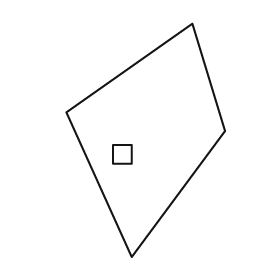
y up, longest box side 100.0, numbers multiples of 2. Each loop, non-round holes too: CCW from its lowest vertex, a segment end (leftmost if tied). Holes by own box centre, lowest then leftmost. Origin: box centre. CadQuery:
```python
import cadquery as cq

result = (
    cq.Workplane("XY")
    .moveTo(-6.0, -50.0)
    .lineTo(34.0, 4.0)
    .lineTo(20.0, 50.0)
    .lineTo(-34.0, 12.0)
    .close()
    .moveTo(-14.0, -10.0)
    .lineTo(-6.0, -10.0)
    .lineTo(-6.0, -2.0)
    .lineTo(-14.0, -2.0)
    .close()
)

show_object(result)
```